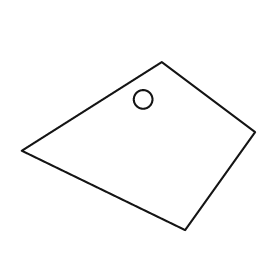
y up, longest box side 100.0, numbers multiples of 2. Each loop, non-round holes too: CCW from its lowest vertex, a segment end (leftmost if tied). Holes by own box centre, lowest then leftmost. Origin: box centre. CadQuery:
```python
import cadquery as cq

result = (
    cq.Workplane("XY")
    .moveTo(20.0, -36.0)
    .lineTo(50.0, 6.0)
    .lineTo(10.0, 36.0)
    .lineTo(-50.0, -2.0)
    .close()
    .moveTo(2.0, 20.0)
    .circle(4.0)
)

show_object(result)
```